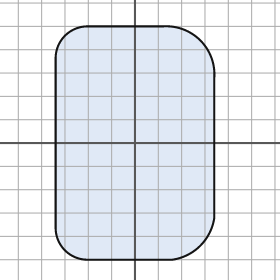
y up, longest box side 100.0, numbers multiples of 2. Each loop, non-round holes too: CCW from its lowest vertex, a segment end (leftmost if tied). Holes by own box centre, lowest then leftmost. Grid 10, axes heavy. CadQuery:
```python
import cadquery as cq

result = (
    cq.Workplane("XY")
    .moveTo(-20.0, -50.0)
    .lineTo(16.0, -50.0)
    .threePointArc((28.0, -44.0), (34.0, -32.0))
    .lineTo(34.0, 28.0)
    .threePointArc((28.0, 44.0), (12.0, 50.0))
    .lineTo(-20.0, 50.0)
    .threePointArc((-30.0, 46.0), (-34.0, 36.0))
    .lineTo(-34.0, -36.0)
    .threePointArc((-30.0, -46.0), (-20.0, -50.0))
    .close()
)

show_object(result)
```